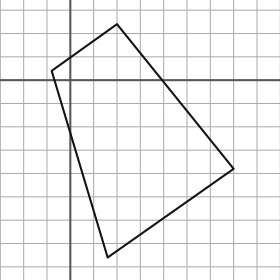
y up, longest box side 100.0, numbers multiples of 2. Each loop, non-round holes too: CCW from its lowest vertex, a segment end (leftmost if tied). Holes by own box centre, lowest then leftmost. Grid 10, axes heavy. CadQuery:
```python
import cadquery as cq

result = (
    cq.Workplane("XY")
    .moveTo(16.0, -76.0)
    .lineTo(70.0, -38.0)
    .lineTo(20.0, 24.0)
    .lineTo(-8.0, 4.0)
    .close()
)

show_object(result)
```